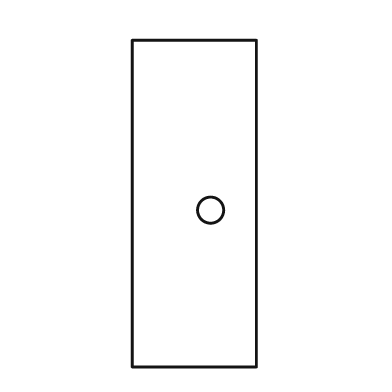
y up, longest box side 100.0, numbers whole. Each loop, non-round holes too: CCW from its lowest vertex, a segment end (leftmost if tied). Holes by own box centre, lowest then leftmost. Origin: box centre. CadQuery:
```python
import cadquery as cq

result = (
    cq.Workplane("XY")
    .moveTo(-19.0, -50.0)
    .lineTo(19.0, -50.0)
    .lineTo(19.0, 50.0)
    .lineTo(-19.0, 50.0)
    .close()
    .moveTo(5.0, -2.0)
    .circle(4.0)
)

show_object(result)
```